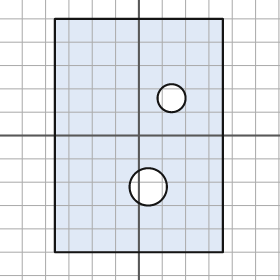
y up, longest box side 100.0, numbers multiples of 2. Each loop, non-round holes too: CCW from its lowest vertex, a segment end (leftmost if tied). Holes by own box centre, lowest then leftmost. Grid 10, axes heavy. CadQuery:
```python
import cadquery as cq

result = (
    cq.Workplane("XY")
    .moveTo(-36.0, -50.0)
    .lineTo(36.0, -50.0)
    .lineTo(36.0, 50.0)
    .lineTo(-36.0, 50.0)
    .close()
    .moveTo(4.0, -22.0)
    .circle(8.0)
    .moveTo(14.0, 16.0)
    .circle(6.0)
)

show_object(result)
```